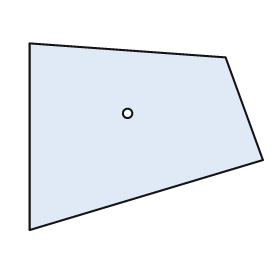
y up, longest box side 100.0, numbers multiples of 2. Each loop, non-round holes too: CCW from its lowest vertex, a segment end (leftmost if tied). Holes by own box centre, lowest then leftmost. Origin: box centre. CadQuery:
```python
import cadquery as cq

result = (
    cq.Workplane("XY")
    .moveTo(-50.0, -40.0)
    .lineTo(50.0, -10.0)
    .lineTo(34.0, 34.0)
    .lineTo(-50.0, 40.0)
    .close()
    .moveTo(-8.0, 10.0)
    .circle(2.0)
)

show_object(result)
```